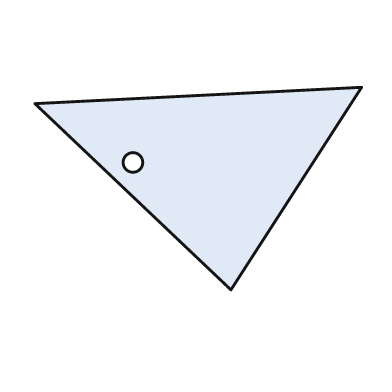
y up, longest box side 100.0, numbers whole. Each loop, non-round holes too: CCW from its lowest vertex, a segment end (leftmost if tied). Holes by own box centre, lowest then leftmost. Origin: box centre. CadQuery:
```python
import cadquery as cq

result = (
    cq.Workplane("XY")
    .moveTo(10.0, -31.0)
    .lineTo(50.0, 31.0)
    .lineTo(-50.0, 26.0)
    .close()
    .moveTo(-20.0, 8.0)
    .circle(3.0)
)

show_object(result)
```